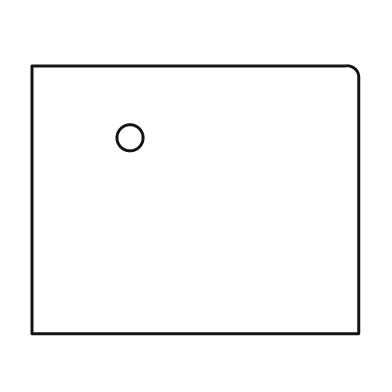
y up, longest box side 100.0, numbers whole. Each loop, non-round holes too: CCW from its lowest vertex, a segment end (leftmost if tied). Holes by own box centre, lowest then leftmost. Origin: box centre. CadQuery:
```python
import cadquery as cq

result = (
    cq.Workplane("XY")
    .moveTo(-50.0, -41.0)
    .lineTo(50.0, -41.0)
    .lineTo(50.0, 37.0)
    .threePointArc((49.0, 40.0), (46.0, 41.0))
    .lineTo(-50.0, 41.0)
    .close()
    .moveTo(-20.0, 19.0)
    .circle(4.0)
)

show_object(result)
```